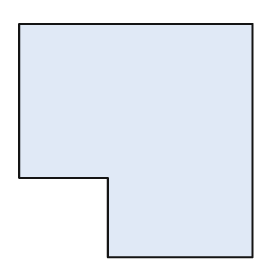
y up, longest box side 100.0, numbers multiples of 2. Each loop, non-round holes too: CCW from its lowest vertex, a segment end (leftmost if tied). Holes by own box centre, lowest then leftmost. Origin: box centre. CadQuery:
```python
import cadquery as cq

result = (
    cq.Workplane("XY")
    .moveTo(-12.0, -50.0)
    .lineTo(50.0, -50.0)
    .lineTo(50.0, 50.0)
    .lineTo(-50.0, 50.0)
    .lineTo(-50.0, -16.0)
    .lineTo(-12.0, -16.0)
    .close()
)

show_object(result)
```